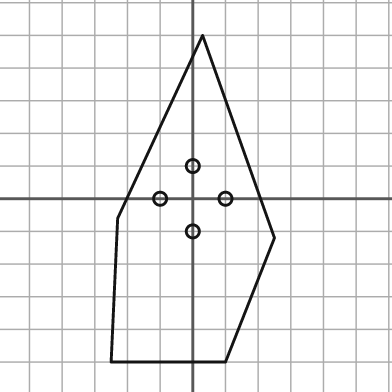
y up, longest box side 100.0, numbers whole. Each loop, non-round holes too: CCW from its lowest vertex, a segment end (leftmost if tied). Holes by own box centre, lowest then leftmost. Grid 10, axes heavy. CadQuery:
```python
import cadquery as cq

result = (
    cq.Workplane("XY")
    .moveTo(-25.0, -50.0)
    .lineTo(10.0, -50.0)
    .lineTo(25.0, -12.0)
    .lineTo(3.0, 50.0)
    .lineTo(-23.0, -6.0)
    .close()
    .moveTo(0.0, -10.0)
    .circle(2.0)
    .moveTo(-10.0, 0.0)
    .circle(2.0)
    .moveTo(10.0, 0.0)
    .circle(2.0)
    .moveTo(0.0, 10.0)
    .circle(2.0)
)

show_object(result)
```